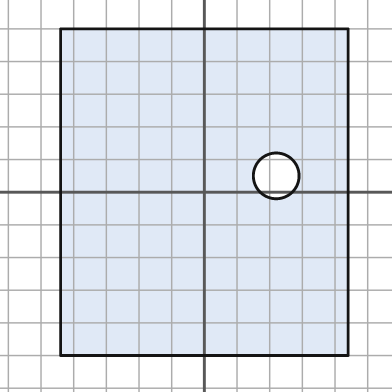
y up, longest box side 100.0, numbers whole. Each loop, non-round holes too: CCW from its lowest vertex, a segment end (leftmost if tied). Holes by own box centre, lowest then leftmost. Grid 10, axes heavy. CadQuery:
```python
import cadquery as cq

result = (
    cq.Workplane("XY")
    .moveTo(-44.0, -50.0)
    .lineTo(44.0, -50.0)
    .lineTo(44.0, 50.0)
    .lineTo(-44.0, 50.0)
    .close()
    .moveTo(22.0, 5.0)
    .circle(7.0)
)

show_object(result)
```